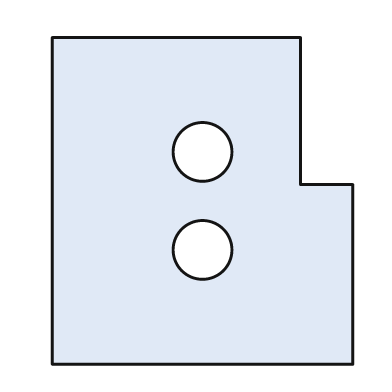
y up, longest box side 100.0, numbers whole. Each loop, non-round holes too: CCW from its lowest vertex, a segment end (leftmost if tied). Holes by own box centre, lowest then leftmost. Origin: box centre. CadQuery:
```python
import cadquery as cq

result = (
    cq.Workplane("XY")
    .moveTo(-46.0, -50.0)
    .lineTo(46.0, -50.0)
    .lineTo(46.0, 5.0)
    .lineTo(30.0, 5.0)
    .lineTo(30.0, 50.0)
    .lineTo(-46.0, 50.0)
    .close()
    .moveTo(0.0, -15.0)
    .circle(9.0)
    .moveTo(0.0, 15.0)
    .circle(9.0)
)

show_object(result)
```